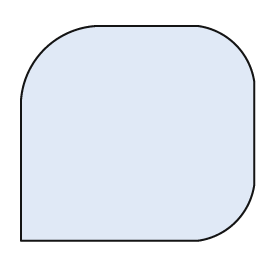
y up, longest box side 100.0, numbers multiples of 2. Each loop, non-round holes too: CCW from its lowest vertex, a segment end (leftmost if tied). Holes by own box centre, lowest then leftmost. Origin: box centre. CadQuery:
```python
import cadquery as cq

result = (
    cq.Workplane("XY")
    .moveTo(-50.0, -46.0)
    .lineTo(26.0, -46.0)
    .threePointArc((42.0, -38.0), (50.0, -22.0))
    .lineTo(50.0, 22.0)
    .threePointArc((42.0, 38.0), (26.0, 46.0))
    .lineTo(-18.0, 46.0)
    .threePointArc((-40.0, 36.0), (-50.0, 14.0))
    .close()
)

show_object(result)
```